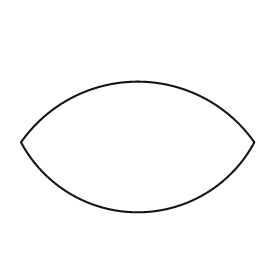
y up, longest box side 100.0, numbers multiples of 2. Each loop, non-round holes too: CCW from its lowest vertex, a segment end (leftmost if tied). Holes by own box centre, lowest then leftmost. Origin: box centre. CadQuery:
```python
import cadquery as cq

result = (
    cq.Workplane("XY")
    .moveTo(-50.0, 2.0)
    .threePointArc((0.0, -28.0), (50.0, 2.0))
    .threePointArc((0.0, 28.0), (-50.0, 2.0))
    .close()
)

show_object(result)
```